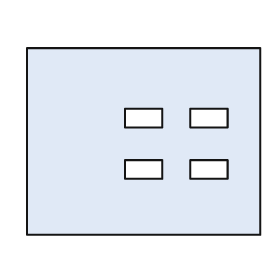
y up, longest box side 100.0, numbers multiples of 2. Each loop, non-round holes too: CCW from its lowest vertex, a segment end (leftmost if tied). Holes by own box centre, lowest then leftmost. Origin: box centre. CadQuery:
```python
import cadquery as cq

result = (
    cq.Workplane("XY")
    .moveTo(-50.0, -40.0)
    .lineTo(50.0, -40.0)
    .lineTo(50.0, 40.0)
    .lineTo(-50.0, 40.0)
    .close()
    .moveTo(-8.0, -16.0)
    .lineTo(8.0, -16.0)
    .lineTo(8.0, -8.0)
    .lineTo(-8.0, -8.0)
    .close()
    .moveTo(20.0, -16.0)
    .lineTo(36.0, -16.0)
    .lineTo(36.0, -8.0)
    .lineTo(20.0, -8.0)
    .close()
    .moveTo(-8.0, 6.0)
    .lineTo(8.0, 6.0)
    .lineTo(8.0, 14.0)
    .lineTo(-8.0, 14.0)
    .close()
    .moveTo(20.0, 6.0)
    .lineTo(36.0, 6.0)
    .lineTo(36.0, 14.0)
    .lineTo(20.0, 14.0)
    .close()
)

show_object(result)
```